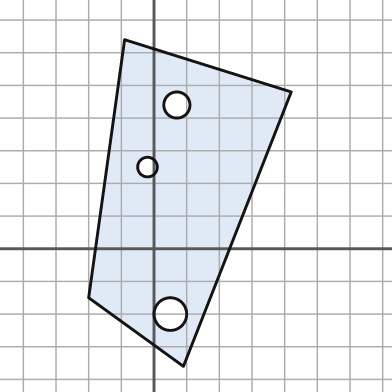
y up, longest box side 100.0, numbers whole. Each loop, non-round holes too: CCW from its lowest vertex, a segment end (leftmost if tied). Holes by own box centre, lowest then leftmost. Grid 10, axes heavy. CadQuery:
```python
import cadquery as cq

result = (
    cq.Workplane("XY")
    .moveTo(9.0, -36.0)
    .lineTo(42.0, 48.0)
    .lineTo(-9.0, 64.0)
    .lineTo(-20.0, -15.0)
    .close()
    .moveTo(5.0, -20.0)
    .circle(5.0)
    .moveTo(-2.0, 25.0)
    .circle(3.0)
    .moveTo(7.0, 44.0)
    .circle(4.0)
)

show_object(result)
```